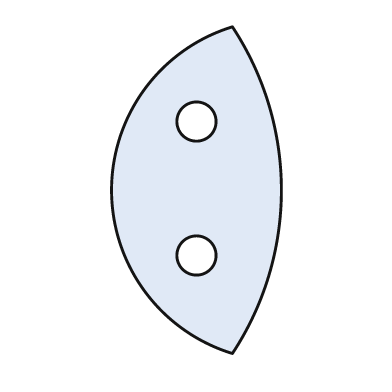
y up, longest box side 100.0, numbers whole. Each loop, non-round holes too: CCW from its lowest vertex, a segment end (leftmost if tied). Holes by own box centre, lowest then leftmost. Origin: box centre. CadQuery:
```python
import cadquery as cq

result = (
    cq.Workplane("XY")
    .moveTo(11.0, -50.0)
    .threePointArc((26.0, 0.0), (11.0, 50.0))
    .threePointArc((-26.0, 0.0), (11.0, -50.0))
    .close()
    .moveTo(0.0, -20.0)
    .circle(6.0)
    .moveTo(0.0, 21.0)
    .circle(6.0)
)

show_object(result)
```